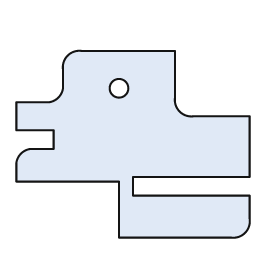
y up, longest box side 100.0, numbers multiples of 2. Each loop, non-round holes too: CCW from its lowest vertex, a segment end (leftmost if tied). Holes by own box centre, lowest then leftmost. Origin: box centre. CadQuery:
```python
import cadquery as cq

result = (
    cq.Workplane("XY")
    .moveTo(-6.0, -40.0)
    .lineTo(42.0, -40.0)
    .threePointArc((48.0, -38.0), (50.0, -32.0))
    .lineTo(50.0, -22.0)
    .lineTo(0.0, -22.0)
    .lineTo(0.0, -14.0)
    .lineTo(50.0, -14.0)
    .lineTo(50.0, 12.0)
    .lineTo(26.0, 12.0)
    .threePointArc((20.0, 14.0), (18.0, 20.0))
    .lineTo(18.0, 40.0)
    .lineTo(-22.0, 40.0)
    .threePointArc((-28.0, 38.0), (-30.0, 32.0))
    .lineTo(-30.0, 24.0)
    .threePointArc((-32.0, 20.0), (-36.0, 18.0))
    .lineTo(-50.0, 18.0)
    .lineTo(-50.0, 6.0)
    .lineTo(-34.0, 6.0)
    .lineTo(-34.0, -2.0)
    .lineTo(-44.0, -2.0)
    .threePointArc((-48.0, -4.0), (-50.0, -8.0))
    .lineTo(-50.0, -16.0)
    .lineTo(-6.0, -16.0)
    .close()
    .moveTo(-6.0, 24.0)
    .circle(4.0)
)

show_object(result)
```